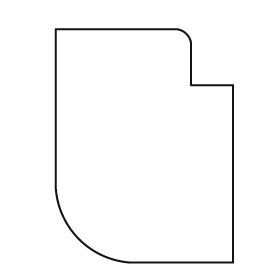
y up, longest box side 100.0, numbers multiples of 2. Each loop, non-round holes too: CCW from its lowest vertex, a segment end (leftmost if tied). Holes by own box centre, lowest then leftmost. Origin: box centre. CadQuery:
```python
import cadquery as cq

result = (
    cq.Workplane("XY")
    .moveTo(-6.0, -50.0)
    .lineTo(38.0, -50.0)
    .lineTo(38.0, 26.0)
    .lineTo(20.0, 26.0)
    .lineTo(20.0, 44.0)
    .threePointArc((18.0, 48.0), (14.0, 50.0))
    .lineTo(-38.0, 50.0)
    .lineTo(-38.0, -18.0)
    .threePointArc((-28.0, -40.0), (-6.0, -50.0))
    .close()
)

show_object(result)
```